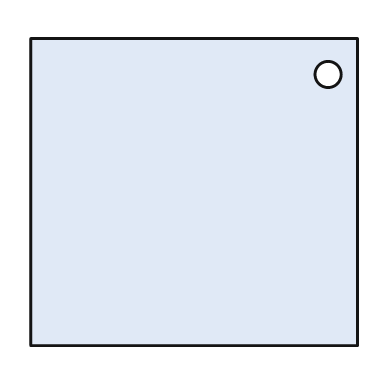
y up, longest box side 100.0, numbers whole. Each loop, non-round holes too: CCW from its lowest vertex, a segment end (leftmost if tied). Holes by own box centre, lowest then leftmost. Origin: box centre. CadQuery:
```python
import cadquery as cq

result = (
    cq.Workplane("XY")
    .moveTo(-50.0, -47.0)
    .lineTo(50.0, -47.0)
    .lineTo(50.0, 47.0)
    .lineTo(-50.0, 47.0)
    .close()
    .moveTo(41.0, 36.0)
    .circle(4.0)
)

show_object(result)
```